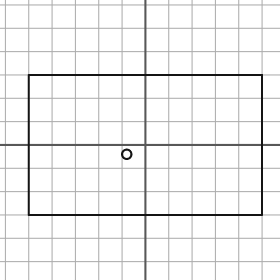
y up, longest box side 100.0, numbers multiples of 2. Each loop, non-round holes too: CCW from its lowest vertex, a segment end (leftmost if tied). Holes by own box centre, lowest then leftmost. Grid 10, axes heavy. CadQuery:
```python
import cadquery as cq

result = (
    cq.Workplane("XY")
    .moveTo(-50.0, -30.0)
    .lineTo(50.0, -30.0)
    .lineTo(50.0, 30.0)
    .lineTo(-50.0, 30.0)
    .close()
    .moveTo(-8.0, -4.0)
    .circle(2.0)
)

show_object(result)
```